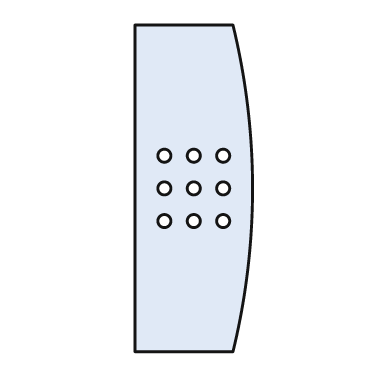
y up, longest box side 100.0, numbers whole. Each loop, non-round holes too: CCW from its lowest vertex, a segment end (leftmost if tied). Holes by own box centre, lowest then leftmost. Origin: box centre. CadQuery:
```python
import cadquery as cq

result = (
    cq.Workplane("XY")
    .moveTo(-18.0, -50.0)
    .lineTo(12.0, -50.0)
    .threePointArc((18.0, 0.0), (12.0, 50.0))
    .lineTo(-18.0, 50.0)
    .close()
    .moveTo(-9.0, -10.0)
    .circle(2.0)
    .moveTo(0.0, -10.0)
    .circle(2.0)
    .moveTo(9.0, -10.0)
    .circle(2.0)
    .moveTo(-9.0, 0.0)
    .circle(2.0)
    .moveTo(0.0, 0.0)
    .circle(2.0)
    .moveTo(9.0, 0.0)
    .circle(2.0)
    .moveTo(-9.0, 10.0)
    .circle(2.0)
    .moveTo(0.0, 10.0)
    .circle(2.0)
    .moveTo(9.0, 10.0)
    .circle(2.0)
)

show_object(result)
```